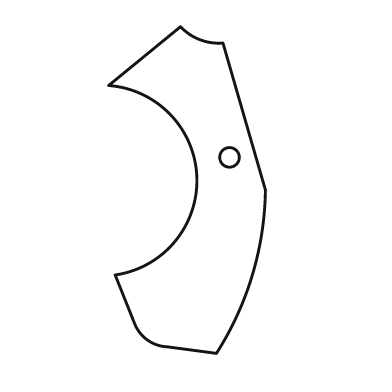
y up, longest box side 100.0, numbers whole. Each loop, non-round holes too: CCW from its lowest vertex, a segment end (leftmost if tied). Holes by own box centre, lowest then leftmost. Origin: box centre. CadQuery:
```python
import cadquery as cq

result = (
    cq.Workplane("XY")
    .moveTo(9.0, -50.0)
    .threePointArc((20.0, -26.0), (24.0, 0.0))
    .lineTo(11.0, 45.0)
    .threePointArc((4.0, 46.0), (-2.0, 50.0))
    .lineTo(-24.0, 32.0)
    .threePointArc((3.0, 4.0), (-22.0, -26.0))
    .lineTo(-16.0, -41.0)
    .threePointArc((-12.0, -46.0), (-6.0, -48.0))
    .close()
    .moveTo(13.0, 10.0)
    .circle(3.0)
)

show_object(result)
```